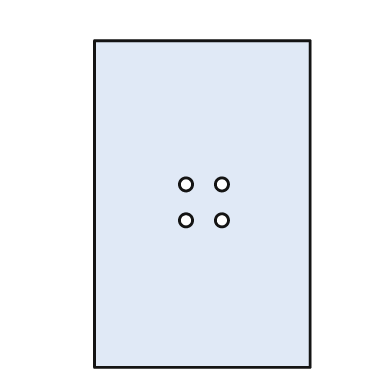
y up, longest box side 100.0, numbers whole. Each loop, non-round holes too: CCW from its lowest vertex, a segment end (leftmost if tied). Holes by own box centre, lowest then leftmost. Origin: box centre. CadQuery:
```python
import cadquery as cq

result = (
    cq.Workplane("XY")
    .moveTo(-33.0, -50.0)
    .lineTo(33.0, -50.0)
    .lineTo(33.0, 50.0)
    .lineTo(-33.0, 50.0)
    .close()
    .moveTo(-5.0, -5.0)
    .circle(2.0)
    .moveTo(6.0, -5.0)
    .circle(2.0)
    .moveTo(-5.0, 6.0)
    .circle(2.0)
    .moveTo(6.0, 6.0)
    .circle(2.0)
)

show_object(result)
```